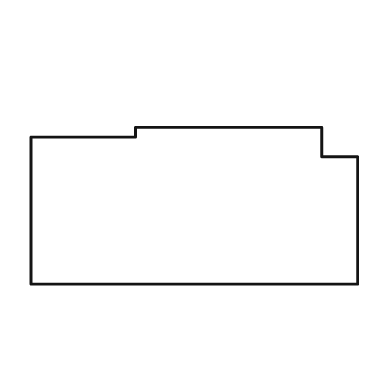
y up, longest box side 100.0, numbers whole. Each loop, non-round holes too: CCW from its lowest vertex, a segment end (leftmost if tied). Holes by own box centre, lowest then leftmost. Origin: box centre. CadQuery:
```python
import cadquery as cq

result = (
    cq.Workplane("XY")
    .moveTo(-50.0, -24.0)
    .lineTo(50.0, -24.0)
    .lineTo(50.0, 15.0)
    .lineTo(39.0, 15.0)
    .lineTo(39.0, 24.0)
    .lineTo(-18.0, 24.0)
    .lineTo(-18.0, 21.0)
    .lineTo(-50.0, 21.0)
    .close()
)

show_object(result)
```